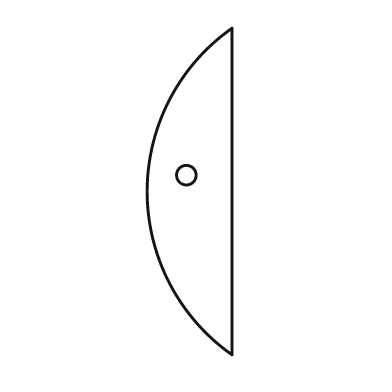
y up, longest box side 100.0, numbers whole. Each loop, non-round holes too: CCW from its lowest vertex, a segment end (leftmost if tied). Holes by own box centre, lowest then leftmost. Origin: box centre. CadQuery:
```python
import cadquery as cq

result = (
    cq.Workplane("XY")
    .moveTo(13.0, -50.0)
    .lineTo(13.0, 50.0)
    .threePointArc((-13.0, 0.0), (13.0, -50.0))
    .close()
    .moveTo(-1.0, 5.0)
    .circle(3.0)
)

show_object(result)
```